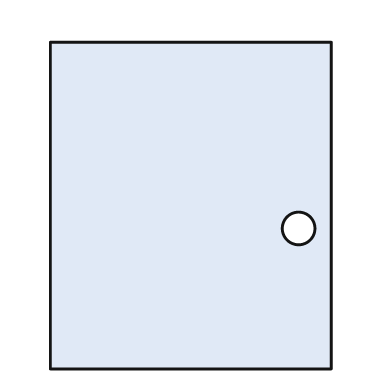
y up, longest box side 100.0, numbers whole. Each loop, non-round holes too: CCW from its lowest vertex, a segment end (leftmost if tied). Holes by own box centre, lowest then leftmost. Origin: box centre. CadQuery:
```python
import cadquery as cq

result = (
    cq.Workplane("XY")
    .moveTo(-43.0, -50.0)
    .lineTo(43.0, -50.0)
    .lineTo(43.0, 50.0)
    .lineTo(-43.0, 50.0)
    .close()
    .moveTo(33.0, -7.0)
    .circle(5.0)
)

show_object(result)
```